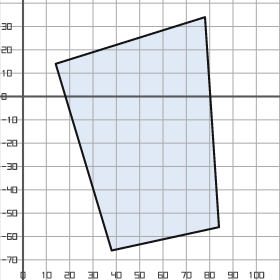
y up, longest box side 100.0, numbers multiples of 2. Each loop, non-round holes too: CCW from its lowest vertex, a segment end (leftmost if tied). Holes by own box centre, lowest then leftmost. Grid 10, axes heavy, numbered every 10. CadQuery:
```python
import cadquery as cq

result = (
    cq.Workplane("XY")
    .moveTo(38.0, -66.0)
    .lineTo(84.0, -56.0)
    .lineTo(78.0, 34.0)
    .lineTo(14.0, 14.0)
    .close()
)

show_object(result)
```